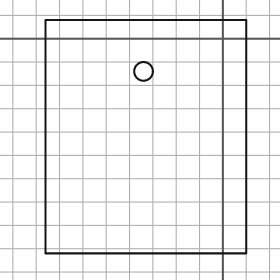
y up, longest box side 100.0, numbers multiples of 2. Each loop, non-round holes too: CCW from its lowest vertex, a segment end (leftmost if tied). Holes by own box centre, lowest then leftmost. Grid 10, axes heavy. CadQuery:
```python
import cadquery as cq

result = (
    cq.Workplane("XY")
    .moveTo(-76.0, -92.0)
    .lineTo(10.0, -92.0)
    .lineTo(10.0, 8.0)
    .lineTo(-76.0, 8.0)
    .close()
    .moveTo(-34.0, -14.0)
    .circle(4.0)
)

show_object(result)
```